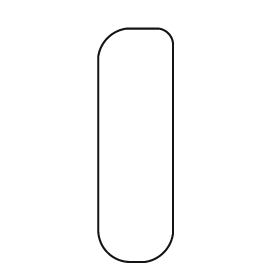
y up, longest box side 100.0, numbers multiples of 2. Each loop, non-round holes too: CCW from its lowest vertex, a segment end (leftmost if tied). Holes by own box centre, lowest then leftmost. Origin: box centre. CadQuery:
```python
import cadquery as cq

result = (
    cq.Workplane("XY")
    .moveTo(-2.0, -50.0)
    .lineTo(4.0, -50.0)
    .threePointArc((12.0, -46.0), (16.0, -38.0))
    .lineTo(16.0, 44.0)
    .threePointArc((14.0, 48.0), (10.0, 50.0))
    .lineTo(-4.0, 50.0)
    .threePointArc((-12.0, 46.0), (-16.0, 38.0))
    .lineTo(-16.0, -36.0)
    .threePointArc((-12.0, -46.0), (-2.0, -50.0))
    .close()
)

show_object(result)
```